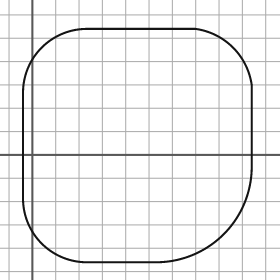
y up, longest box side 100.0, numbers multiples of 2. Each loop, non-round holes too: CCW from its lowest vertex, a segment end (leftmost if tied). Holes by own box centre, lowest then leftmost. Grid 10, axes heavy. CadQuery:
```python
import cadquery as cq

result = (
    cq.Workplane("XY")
    .moveTo(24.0, -46.0)
    .lineTo(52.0, -46.0)
    .threePointArc((82.0, -34.0), (94.0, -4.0))
    .lineTo(94.0, 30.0)
    .threePointArc((86.0, 46.0), (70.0, 54.0))
    .lineTo(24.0, 54.0)
    .threePointArc((4.0, 46.0), (-4.0, 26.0))
    .lineTo(-4.0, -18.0)
    .threePointArc((4.0, -38.0), (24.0, -46.0))
    .close()
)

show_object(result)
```